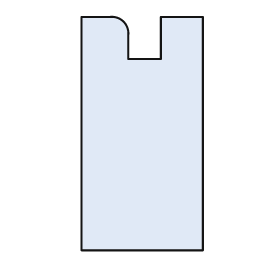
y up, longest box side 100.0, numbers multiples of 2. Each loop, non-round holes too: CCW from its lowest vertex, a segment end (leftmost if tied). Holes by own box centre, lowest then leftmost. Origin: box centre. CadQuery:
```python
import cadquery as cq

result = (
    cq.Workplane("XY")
    .moveTo(-26.0, -50.0)
    .lineTo(26.0, -50.0)
    .lineTo(26.0, 50.0)
    .lineTo(8.0, 50.0)
    .lineTo(8.0, 32.0)
    .lineTo(-6.0, 32.0)
    .lineTo(-6.0, 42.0)
    .threePointArc((-8.0, 48.0), (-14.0, 50.0))
    .lineTo(-26.0, 50.0)
    .close()
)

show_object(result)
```